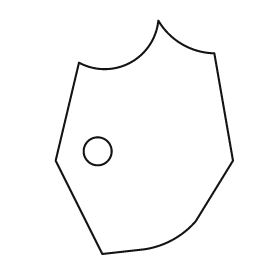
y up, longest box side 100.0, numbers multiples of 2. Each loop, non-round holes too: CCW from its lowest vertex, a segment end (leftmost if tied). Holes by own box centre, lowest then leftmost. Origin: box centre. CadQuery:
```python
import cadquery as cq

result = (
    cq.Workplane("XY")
    .moveTo(-18.0, -50.0)
    .lineTo(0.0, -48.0)
    .threePointArc((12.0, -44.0), (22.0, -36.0))
    .lineTo(38.0, -10.0)
    .lineTo(30.0, 36.0)
    .threePointArc((16.0, 40.0), (6.0, 50.0))
    .threePointArc((-6.0, 32.0), (-28.0, 32.0))
    .lineTo(-38.0, -10.0)
    .close()
    .moveTo(-20.0, -6.0)
    .circle(6.0)
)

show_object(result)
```